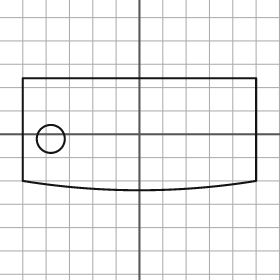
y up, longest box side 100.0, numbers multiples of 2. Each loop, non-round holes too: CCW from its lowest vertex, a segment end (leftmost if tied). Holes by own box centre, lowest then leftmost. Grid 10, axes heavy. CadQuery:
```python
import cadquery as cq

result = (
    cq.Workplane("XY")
    .moveTo(-50.0, -20.0)
    .threePointArc((0.0, -24.0), (50.0, -20.0))
    .lineTo(50.0, 24.0)
    .lineTo(-50.0, 24.0)
    .close()
    .moveTo(-38.0, -2.0)
    .circle(6.0)
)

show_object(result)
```